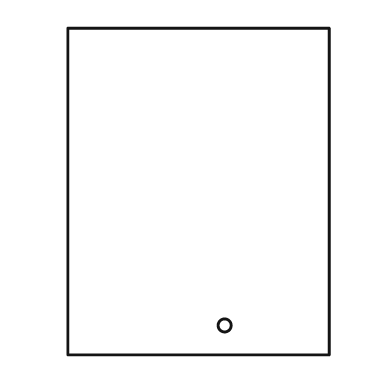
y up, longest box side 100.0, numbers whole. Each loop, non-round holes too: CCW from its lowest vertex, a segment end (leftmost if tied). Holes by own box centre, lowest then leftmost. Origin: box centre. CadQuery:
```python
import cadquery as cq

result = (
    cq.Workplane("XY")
    .moveTo(-40.0, -50.0)
    .lineTo(40.0, -50.0)
    .lineTo(40.0, 50.0)
    .lineTo(-40.0, 50.0)
    .close()
    .moveTo(8.0, -41.0)
    .circle(2.0)
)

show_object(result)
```